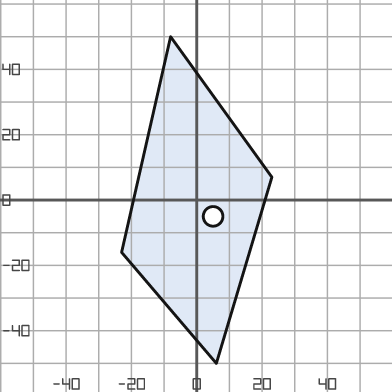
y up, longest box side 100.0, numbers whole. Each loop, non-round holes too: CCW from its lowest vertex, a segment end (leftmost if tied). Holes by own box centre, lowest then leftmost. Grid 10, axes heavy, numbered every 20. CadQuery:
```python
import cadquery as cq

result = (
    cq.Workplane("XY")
    .moveTo(6.0, -50.0)
    .lineTo(23.0, 7.0)
    .lineTo(-8.0, 50.0)
    .lineTo(-23.0, -16.0)
    .close()
    .moveTo(5.0, -5.0)
    .circle(3.0)
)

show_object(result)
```